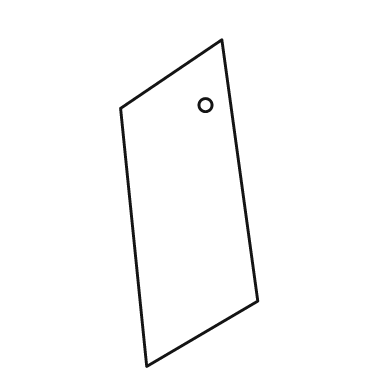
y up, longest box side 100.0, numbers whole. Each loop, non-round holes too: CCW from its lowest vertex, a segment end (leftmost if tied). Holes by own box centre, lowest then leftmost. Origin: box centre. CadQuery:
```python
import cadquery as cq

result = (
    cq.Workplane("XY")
    .moveTo(-13.0, -50.0)
    .lineTo(21.0, -30.0)
    .lineTo(10.0, 50.0)
    .lineTo(-21.0, 29.0)
    .close()
    .moveTo(5.0, 30.0)
    .circle(2.0)
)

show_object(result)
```